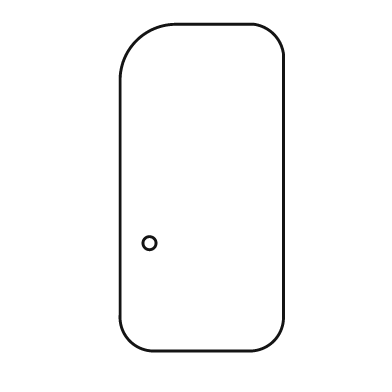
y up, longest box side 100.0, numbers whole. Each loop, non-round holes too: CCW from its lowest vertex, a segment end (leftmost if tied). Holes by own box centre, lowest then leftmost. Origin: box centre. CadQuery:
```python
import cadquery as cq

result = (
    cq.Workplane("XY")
    .moveTo(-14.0, -50.0)
    .lineTo(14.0, -50.0)
    .threePointArc((22.0, -47.0), (25.0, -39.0))
    .lineTo(25.0, 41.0)
    .threePointArc((22.0, 47.0), (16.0, 50.0))
    .lineTo(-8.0, 50.0)
    .threePointArc((-20.0, 45.0), (-25.0, 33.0))
    .lineTo(-25.0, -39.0)
    .threePointArc((-22.0, -47.0), (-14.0, -50.0))
    .close()
    .moveTo(-16.0, -17.0)
    .circle(2.0)
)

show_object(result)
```